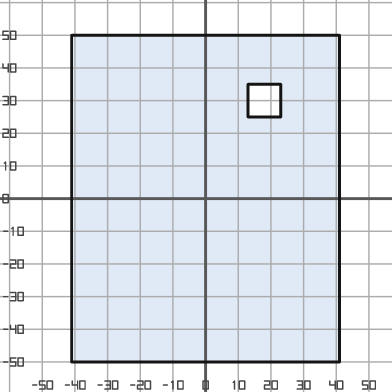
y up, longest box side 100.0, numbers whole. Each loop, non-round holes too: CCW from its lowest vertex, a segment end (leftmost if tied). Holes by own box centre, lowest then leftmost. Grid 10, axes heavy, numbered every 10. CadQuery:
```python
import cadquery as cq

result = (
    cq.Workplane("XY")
    .moveTo(-41.0, -50.0)
    .lineTo(41.0, -50.0)
    .lineTo(41.0, 50.0)
    .lineTo(-41.0, 50.0)
    .close()
    .moveTo(13.0, 25.0)
    .lineTo(23.0, 25.0)
    .lineTo(23.0, 35.0)
    .lineTo(13.0, 35.0)
    .close()
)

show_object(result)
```